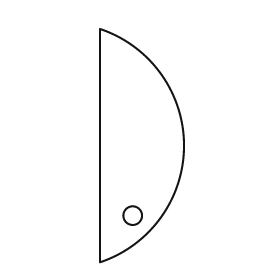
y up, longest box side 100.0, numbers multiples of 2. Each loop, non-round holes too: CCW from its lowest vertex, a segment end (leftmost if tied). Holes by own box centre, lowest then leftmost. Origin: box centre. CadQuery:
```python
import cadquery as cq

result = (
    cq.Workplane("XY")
    .moveTo(-18.0, -50.0)
    .threePointArc((18.0, 0.0), (-18.0, 50.0))
    .close()
    .moveTo(-4.0, -30.0)
    .circle(4.0)
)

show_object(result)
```